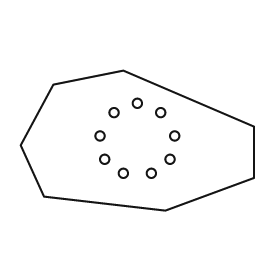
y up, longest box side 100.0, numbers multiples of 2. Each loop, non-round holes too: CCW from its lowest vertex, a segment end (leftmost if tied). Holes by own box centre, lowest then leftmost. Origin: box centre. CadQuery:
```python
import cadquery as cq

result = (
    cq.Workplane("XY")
    .moveTo(12.0, -30.0)
    .lineTo(50.0, -16.0)
    .lineTo(50.0, 6.0)
    .lineTo(-6.0, 30.0)
    .lineTo(-36.0, 24.0)
    .lineTo(-50.0, -2.0)
    .lineTo(-40.0, -24.0)
    .close()
    .moveTo(-6.0, -14.0)
    .circle(2.0)
    .moveTo(6.0, -14.0)
    .circle(2.0)
    .moveTo(-14.0, -8.0)
    .circle(2.0)
    .moveTo(14.0, -8.0)
    .circle(2.0)
    .moveTo(-16.0, 2.0)
    .circle(2.0)
    .moveTo(16.0, 2.0)
    .circle(2.0)
    .moveTo(-10.0, 12.0)
    .circle(2.0)
    .moveTo(10.0, 12.0)
    .circle(2.0)
    .moveTo(0.0, 16.0)
    .circle(2.0)
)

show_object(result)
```